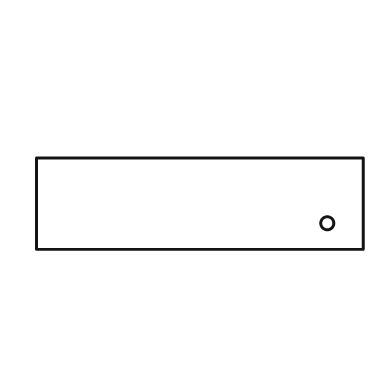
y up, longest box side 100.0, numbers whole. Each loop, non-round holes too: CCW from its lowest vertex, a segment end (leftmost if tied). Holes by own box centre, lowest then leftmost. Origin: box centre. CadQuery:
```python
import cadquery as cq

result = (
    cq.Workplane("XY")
    .moveTo(-50.0, -14.0)
    .lineTo(50.0, -14.0)
    .lineTo(50.0, 14.0)
    .lineTo(-50.0, 14.0)
    .close()
    .moveTo(39.0, -6.0)
    .circle(2.0)
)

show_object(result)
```